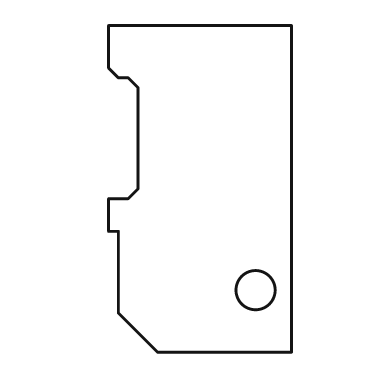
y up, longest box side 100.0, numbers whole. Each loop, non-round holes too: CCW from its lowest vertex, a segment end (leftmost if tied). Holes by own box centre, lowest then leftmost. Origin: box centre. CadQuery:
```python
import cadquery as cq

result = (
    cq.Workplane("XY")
    .moveTo(-13.0, -50.0)
    .lineTo(28.0, -50.0)
    .lineTo(28.0, 50.0)
    .lineTo(-28.0, 50.0)
    .lineTo(-28.0, 37.0)
    .lineTo(-25.0, 34.0)
    .lineTo(-22.0, 34.0)
    .lineTo(-19.0, 31.0)
    .lineTo(-19.0, 0.0)
    .lineTo(-22.0, -3.0)
    .lineTo(-28.0, -3.0)
    .lineTo(-28.0, -13.0)
    .lineTo(-25.0, -13.0)
    .lineTo(-25.0, -38.0)
    .close()
    .moveTo(17.0, -31.0)
    .circle(6.0)
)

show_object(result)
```